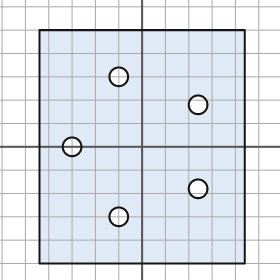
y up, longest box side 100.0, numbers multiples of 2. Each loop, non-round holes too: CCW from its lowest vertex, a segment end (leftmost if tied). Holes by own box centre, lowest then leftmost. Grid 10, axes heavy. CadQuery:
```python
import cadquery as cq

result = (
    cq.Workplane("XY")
    .moveTo(-44.0, -50.0)
    .lineTo(44.0, -50.0)
    .lineTo(44.0, 50.0)
    .lineTo(-44.0, 50.0)
    .close()
    .moveTo(-10.0, -30.0)
    .circle(4.0)
    .moveTo(24.0, -18.0)
    .circle(4.0)
    .moveTo(-30.0, 0.0)
    .circle(4.0)
    .moveTo(24.0, 18.0)
    .circle(4.0)
    .moveTo(-10.0, 30.0)
    .circle(4.0)
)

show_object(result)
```